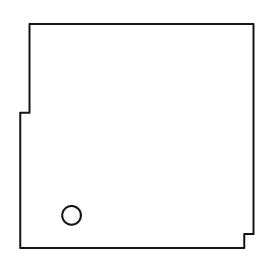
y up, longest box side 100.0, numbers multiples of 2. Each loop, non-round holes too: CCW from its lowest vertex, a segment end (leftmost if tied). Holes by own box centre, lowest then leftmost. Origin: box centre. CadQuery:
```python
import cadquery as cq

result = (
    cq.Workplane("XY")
    .moveTo(-50.0, -48.0)
    .lineTo(46.0, -48.0)
    .lineTo(46.0, -42.0)
    .lineTo(50.0, -42.0)
    .lineTo(50.0, 48.0)
    .lineTo(-46.0, 48.0)
    .lineTo(-46.0, 10.0)
    .lineTo(-50.0, 10.0)
    .close()
    .moveTo(-28.0, -34.0)
    .circle(4.0)
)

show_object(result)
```